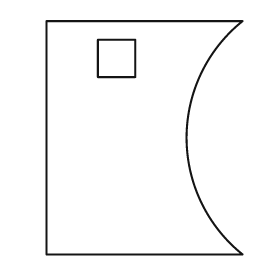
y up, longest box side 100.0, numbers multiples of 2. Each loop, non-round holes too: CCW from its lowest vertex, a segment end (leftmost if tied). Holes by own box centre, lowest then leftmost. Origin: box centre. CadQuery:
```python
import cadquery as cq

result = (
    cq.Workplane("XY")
    .moveTo(-42.0, -50.0)
    .lineTo(42.0, -50.0)
    .threePointArc((18.0, 0.0), (42.0, 50.0))
    .lineTo(-42.0, 50.0)
    .close()
    .moveTo(-20.0, 26.0)
    .lineTo(-4.0, 26.0)
    .lineTo(-4.0, 42.0)
    .lineTo(-20.0, 42.0)
    .close()
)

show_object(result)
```